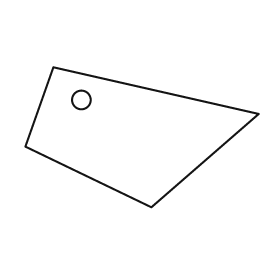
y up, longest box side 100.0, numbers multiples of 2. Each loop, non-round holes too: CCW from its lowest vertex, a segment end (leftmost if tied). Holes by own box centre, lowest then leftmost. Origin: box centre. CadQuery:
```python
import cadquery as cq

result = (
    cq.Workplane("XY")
    .moveTo(4.0, -30.0)
    .lineTo(50.0, 10.0)
    .lineTo(-38.0, 30.0)
    .lineTo(-50.0, -4.0)
    .close()
    .moveTo(-26.0, 16.0)
    .circle(4.0)
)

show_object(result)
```